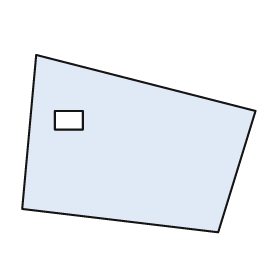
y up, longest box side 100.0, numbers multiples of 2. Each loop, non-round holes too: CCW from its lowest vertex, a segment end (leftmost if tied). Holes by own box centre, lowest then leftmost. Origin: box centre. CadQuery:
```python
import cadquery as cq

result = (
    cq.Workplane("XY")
    .moveTo(34.0, -38.0)
    .lineTo(50.0, 14.0)
    .lineTo(-44.0, 38.0)
    .lineTo(-50.0, -28.0)
    .close()
    .moveTo(-36.0, 6.0)
    .lineTo(-24.0, 6.0)
    .lineTo(-24.0, 14.0)
    .lineTo(-36.0, 14.0)
    .close()
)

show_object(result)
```